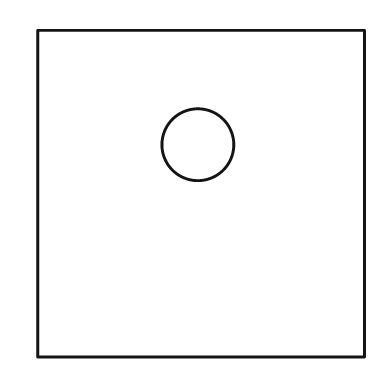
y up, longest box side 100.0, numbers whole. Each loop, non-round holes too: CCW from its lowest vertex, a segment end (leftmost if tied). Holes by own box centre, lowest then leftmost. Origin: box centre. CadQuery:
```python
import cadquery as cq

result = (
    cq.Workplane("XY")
    .moveTo(-50.0, -50.0)
    .lineTo(50.0, -50.0)
    .lineTo(50.0, 50.0)
    .lineTo(-50.0, 50.0)
    .close()
    .moveTo(-1.0, 15.0)
    .circle(11.0)
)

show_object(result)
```